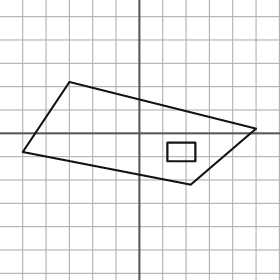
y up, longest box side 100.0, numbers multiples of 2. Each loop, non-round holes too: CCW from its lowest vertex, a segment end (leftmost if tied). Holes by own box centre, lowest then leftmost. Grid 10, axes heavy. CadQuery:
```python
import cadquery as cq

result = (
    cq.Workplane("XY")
    .moveTo(22.0, -22.0)
    .lineTo(50.0, 2.0)
    .lineTo(-30.0, 22.0)
    .lineTo(-50.0, -8.0)
    .close()
    .moveTo(12.0, -12.0)
    .lineTo(24.0, -12.0)
    .lineTo(24.0, -4.0)
    .lineTo(12.0, -4.0)
    .close()
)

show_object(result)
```